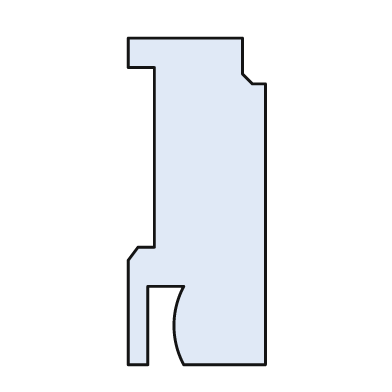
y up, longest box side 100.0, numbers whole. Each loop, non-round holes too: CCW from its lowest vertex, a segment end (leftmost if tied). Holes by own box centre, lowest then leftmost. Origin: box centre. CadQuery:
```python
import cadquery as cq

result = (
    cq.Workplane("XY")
    .moveTo(-21.0, -50.0)
    .lineTo(-15.0, -50.0)
    .lineTo(-15.0, -26.0)
    .lineTo(-4.0, -26.0)
    .threePointArc((-7.0, -38.0), (-4.0, -50.0))
    .lineTo(21.0, -50.0)
    .lineTo(21.0, 36.0)
    .lineTo(17.0, 36.0)
    .lineTo(14.0, 39.0)
    .lineTo(14.0, 50.0)
    .lineTo(-21.0, 50.0)
    .lineTo(-21.0, 41.0)
    .lineTo(-13.0, 41.0)
    .lineTo(-13.0, -14.0)
    .lineTo(-18.0, -14.0)
    .lineTo(-21.0, -18.0)
    .close()
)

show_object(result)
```